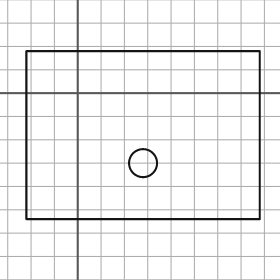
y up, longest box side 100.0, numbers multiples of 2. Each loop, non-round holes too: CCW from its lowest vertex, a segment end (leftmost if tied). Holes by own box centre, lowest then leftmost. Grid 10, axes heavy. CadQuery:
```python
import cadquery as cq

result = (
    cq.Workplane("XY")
    .moveTo(-22.0, -54.0)
    .lineTo(78.0, -54.0)
    .lineTo(78.0, 18.0)
    .lineTo(-22.0, 18.0)
    .close()
    .moveTo(28.0, -30.0)
    .circle(6.0)
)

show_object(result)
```